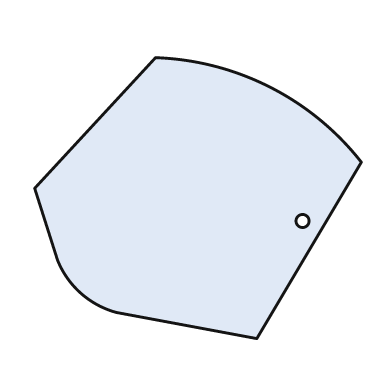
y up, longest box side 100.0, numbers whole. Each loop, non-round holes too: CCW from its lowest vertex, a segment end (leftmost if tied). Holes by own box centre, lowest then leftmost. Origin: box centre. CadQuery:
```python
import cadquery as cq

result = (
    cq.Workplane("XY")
    .moveTo(18.0, -43.0)
    .lineTo(50.0, 11.0)
    .threePointArc((22.0, 34.0), (-13.0, 43.0))
    .lineTo(-50.0, 3.0)
    .lineTo(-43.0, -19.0)
    .threePointArc((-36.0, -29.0), (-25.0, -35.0))
    .close()
    .moveTo(32.0, -7.0)
    .circle(2.0)
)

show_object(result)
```